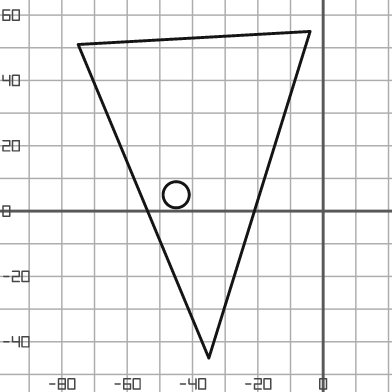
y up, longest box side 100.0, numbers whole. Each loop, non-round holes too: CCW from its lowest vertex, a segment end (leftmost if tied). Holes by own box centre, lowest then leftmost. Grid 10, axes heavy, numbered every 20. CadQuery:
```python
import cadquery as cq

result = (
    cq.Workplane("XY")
    .moveTo(-35.0, -45.0)
    .lineTo(-4.0, 55.0)
    .lineTo(-75.0, 51.0)
    .close()
    .moveTo(-45.0, 5.0)
    .circle(4.0)
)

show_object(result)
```